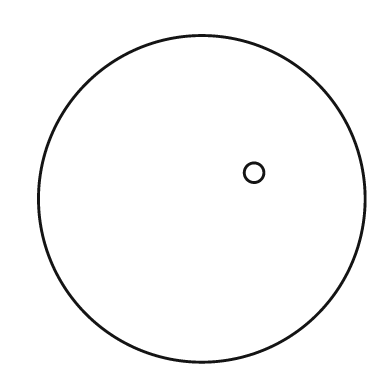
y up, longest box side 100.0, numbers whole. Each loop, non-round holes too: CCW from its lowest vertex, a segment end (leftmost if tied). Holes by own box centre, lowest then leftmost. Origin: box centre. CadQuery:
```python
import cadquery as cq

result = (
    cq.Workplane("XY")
    .moveTo(0.0, 0.0)
    .circle(50.0)
    .moveTo(16.0, 8.0)
    .circle(3.0)
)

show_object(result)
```